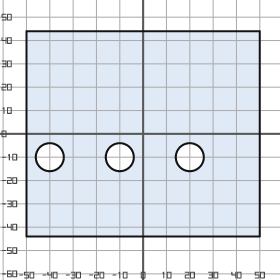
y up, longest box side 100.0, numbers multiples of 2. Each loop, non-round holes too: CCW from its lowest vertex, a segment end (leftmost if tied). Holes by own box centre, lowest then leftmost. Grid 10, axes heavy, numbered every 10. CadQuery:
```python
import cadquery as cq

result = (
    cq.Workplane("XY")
    .moveTo(-50.0, -44.0)
    .lineTo(50.0, -44.0)
    .lineTo(50.0, 44.0)
    .lineTo(-50.0, 44.0)
    .close()
    .moveTo(-40.0, -10.0)
    .circle(6.0)
    .moveTo(-10.0, -10.0)
    .circle(6.0)
    .moveTo(20.0, -10.0)
    .circle(6.0)
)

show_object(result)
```